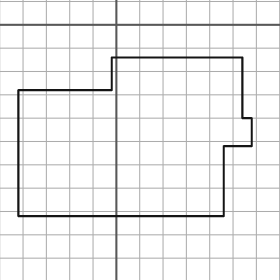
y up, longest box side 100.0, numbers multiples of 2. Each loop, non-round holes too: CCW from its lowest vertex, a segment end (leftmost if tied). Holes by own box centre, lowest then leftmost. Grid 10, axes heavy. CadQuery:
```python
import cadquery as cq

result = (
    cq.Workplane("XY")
    .moveTo(-42.0, -82.0)
    .lineTo(46.0, -82.0)
    .lineTo(46.0, -52.0)
    .lineTo(58.0, -52.0)
    .lineTo(58.0, -40.0)
    .lineTo(54.0, -40.0)
    .lineTo(54.0, -14.0)
    .lineTo(-2.0, -14.0)
    .lineTo(-2.0, -28.0)
    .lineTo(-42.0, -28.0)
    .close()
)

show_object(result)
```